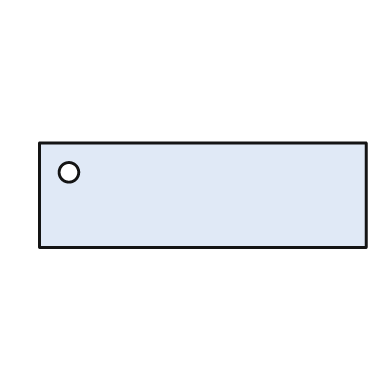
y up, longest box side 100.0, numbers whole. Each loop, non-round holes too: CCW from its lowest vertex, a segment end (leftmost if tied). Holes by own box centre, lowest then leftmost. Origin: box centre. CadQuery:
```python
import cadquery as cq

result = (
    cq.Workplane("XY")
    .moveTo(-50.0, -16.0)
    .lineTo(50.0, -16.0)
    .lineTo(50.0, 16.0)
    .lineTo(-50.0, 16.0)
    .close()
    .moveTo(-41.0, 7.0)
    .circle(3.0)
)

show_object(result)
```